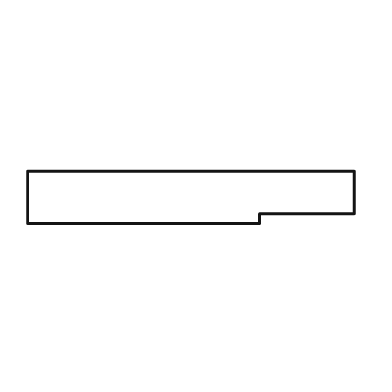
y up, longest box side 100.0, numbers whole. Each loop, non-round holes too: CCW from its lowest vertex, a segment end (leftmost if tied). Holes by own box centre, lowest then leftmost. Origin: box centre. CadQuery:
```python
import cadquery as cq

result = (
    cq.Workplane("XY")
    .moveTo(-50.0, -8.0)
    .lineTo(21.0, -8.0)
    .lineTo(21.0, -5.0)
    .lineTo(50.0, -5.0)
    .lineTo(50.0, 8.0)
    .lineTo(-50.0, 8.0)
    .close()
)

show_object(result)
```